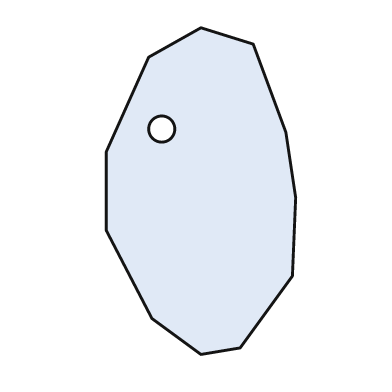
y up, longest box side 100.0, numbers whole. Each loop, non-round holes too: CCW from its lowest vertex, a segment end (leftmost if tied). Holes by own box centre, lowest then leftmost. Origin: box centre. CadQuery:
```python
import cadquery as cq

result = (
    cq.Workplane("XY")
    .moveTo(0.0, -50.0)
    .lineTo(12.0, -48.0)
    .lineTo(28.0, -26.0)
    .lineTo(29.0, -2.0)
    .lineTo(26.0, 18.0)
    .lineTo(16.0, 45.0)
    .lineTo(0.0, 50.0)
    .lineTo(-16.0, 41.0)
    .lineTo(-29.0, 12.0)
    .lineTo(-29.0, -12.0)
    .lineTo(-15.0, -39.0)
    .close()
    .moveTo(-12.0, 19.0)
    .circle(4.0)
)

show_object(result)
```